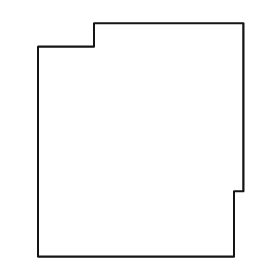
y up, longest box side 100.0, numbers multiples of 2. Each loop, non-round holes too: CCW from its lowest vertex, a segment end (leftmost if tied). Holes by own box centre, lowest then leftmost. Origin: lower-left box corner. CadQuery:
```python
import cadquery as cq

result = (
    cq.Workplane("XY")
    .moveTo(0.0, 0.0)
    .lineTo(84.0, 0.0)
    .lineTo(84.0, 28.0)
    .lineTo(88.0, 28.0)
    .lineTo(88.0, 100.0)
    .lineTo(24.0, 100.0)
    .lineTo(24.0, 90.0)
    .lineTo(0.0, 90.0)
    .close()
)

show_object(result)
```